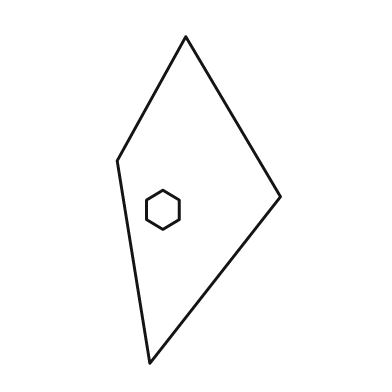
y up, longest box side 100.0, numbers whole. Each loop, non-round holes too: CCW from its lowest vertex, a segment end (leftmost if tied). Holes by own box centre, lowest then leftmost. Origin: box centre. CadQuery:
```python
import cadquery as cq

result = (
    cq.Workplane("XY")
    .moveTo(-15.0, -50.0)
    .lineTo(25.0, 1.0)
    .lineTo(-4.0, 50.0)
    .lineTo(-25.0, 12.0)
    .close()
    .moveTo(-11.0, -9.0)
    .lineTo(-6.0, -6.0)
    .lineTo(-6.0, 0.0)
    .lineTo(-11.0, 3.0)
    .lineTo(-16.0, 0.0)
    .lineTo(-16.0, -6.0)
    .close()
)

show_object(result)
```